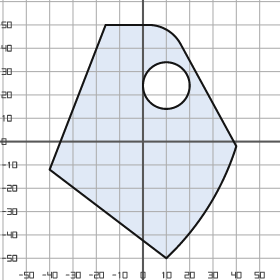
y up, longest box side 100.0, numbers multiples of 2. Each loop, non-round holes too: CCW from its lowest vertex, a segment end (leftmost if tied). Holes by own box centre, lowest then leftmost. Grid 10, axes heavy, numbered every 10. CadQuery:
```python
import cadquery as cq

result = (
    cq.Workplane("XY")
    .moveTo(10.0, -50.0)
    .threePointArc((28.0, -28.0), (40.0, -2.0))
    .lineTo(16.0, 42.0)
    .threePointArc((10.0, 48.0), (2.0, 50.0))
    .lineTo(-16.0, 50.0)
    .lineTo(-40.0, -12.0)
    .close()
    .moveTo(10.0, 24.0)
    .circle(10.0)
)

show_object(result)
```